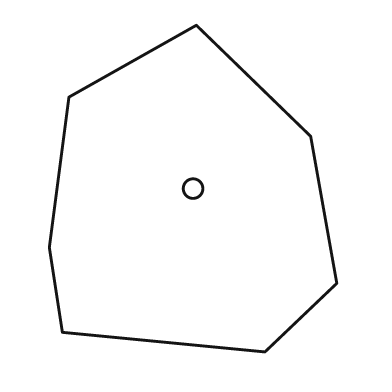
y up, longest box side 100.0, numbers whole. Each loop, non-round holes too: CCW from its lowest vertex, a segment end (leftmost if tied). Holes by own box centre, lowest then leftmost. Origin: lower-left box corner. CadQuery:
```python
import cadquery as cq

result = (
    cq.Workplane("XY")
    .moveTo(66.0, 0.0)
    .lineTo(88.0, 21.0)
    .lineTo(80.0, 66.0)
    .lineTo(45.0, 100.0)
    .lineTo(6.0, 78.0)
    .lineTo(0.0, 32.0)
    .lineTo(4.0, 6.0)
    .close()
    .moveTo(44.0, 50.0)
    .circle(3.0)
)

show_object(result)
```